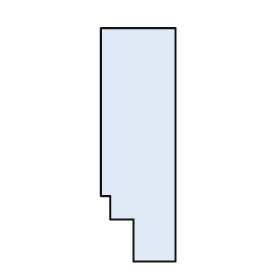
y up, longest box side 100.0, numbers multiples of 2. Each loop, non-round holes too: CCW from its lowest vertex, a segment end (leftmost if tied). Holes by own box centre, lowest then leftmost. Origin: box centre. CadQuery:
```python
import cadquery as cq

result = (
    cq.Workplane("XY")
    .moveTo(-2.0, -50.0)
    .lineTo(16.0, -50.0)
    .lineTo(16.0, 50.0)
    .lineTo(-16.0, 50.0)
    .lineTo(-16.0, -22.0)
    .lineTo(-12.0, -22.0)
    .lineTo(-12.0, -32.0)
    .lineTo(-2.0, -32.0)
    .close()
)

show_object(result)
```